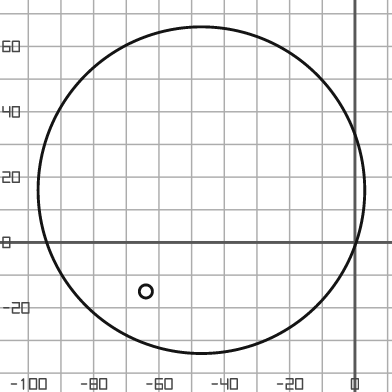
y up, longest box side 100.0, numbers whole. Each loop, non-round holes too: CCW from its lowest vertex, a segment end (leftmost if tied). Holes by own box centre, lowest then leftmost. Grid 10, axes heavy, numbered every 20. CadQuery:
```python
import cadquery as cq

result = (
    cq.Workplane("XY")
    .moveTo(-47.0, 16.0)
    .circle(50.0)
    .moveTo(-64.0, -15.0)
    .circle(2.0)
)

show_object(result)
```